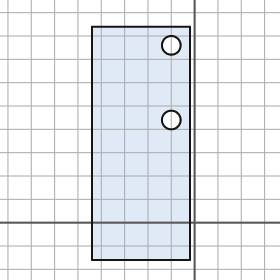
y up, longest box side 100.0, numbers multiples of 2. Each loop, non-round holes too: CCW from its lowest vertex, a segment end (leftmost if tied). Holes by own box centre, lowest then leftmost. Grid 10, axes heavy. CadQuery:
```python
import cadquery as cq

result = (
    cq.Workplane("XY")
    .moveTo(-44.0, -16.0)
    .lineTo(-2.0, -16.0)
    .lineTo(-2.0, 84.0)
    .lineTo(-44.0, 84.0)
    .close()
    .moveTo(-10.0, 44.0)
    .circle(4.0)
    .moveTo(-10.0, 76.0)
    .circle(4.0)
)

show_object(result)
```